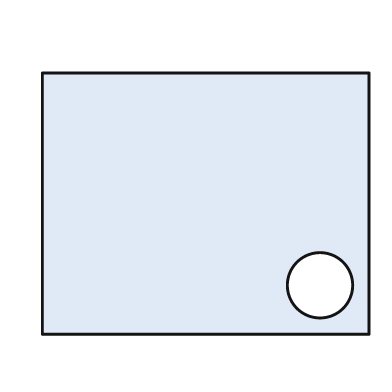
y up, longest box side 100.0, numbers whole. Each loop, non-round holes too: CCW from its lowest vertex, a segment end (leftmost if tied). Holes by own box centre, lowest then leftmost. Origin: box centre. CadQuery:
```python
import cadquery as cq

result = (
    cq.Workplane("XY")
    .moveTo(-50.0, -40.0)
    .lineTo(50.0, -40.0)
    .lineTo(50.0, 40.0)
    .lineTo(-50.0, 40.0)
    .close()
    .moveTo(35.0, -25.0)
    .circle(10.0)
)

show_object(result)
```